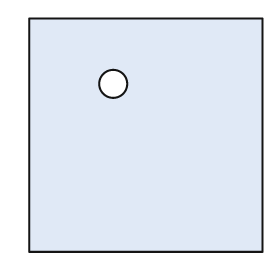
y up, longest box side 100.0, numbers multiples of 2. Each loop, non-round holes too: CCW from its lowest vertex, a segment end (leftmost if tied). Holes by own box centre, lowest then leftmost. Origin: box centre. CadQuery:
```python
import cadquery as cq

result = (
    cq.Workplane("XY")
    .moveTo(-50.0, -50.0)
    .lineTo(50.0, -50.0)
    .lineTo(50.0, 50.0)
    .lineTo(-50.0, 50.0)
    .close()
    .moveTo(-14.0, 22.0)
    .circle(6.0)
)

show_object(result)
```